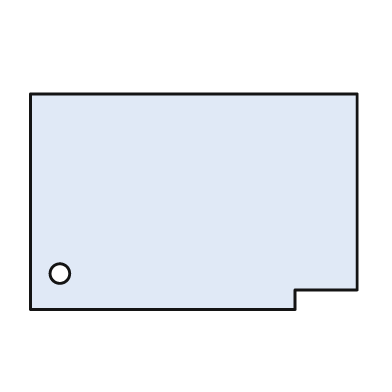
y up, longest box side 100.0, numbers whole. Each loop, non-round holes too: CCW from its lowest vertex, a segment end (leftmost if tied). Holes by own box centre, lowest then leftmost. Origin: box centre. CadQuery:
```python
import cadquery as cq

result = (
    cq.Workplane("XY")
    .moveTo(-50.0, -33.0)
    .lineTo(31.0, -33.0)
    .lineTo(31.0, -27.0)
    .lineTo(50.0, -27.0)
    .lineTo(50.0, 33.0)
    .lineTo(-50.0, 33.0)
    .close()
    .moveTo(-41.0, -22.0)
    .circle(3.0)
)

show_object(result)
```